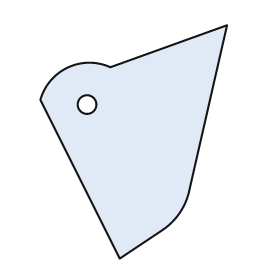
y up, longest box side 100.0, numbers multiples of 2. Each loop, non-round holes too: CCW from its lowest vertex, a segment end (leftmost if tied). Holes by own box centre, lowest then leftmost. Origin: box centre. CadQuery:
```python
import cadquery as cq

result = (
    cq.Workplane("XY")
    .moveTo(-6.0, -50.0)
    .lineTo(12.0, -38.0)
    .threePointArc((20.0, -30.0), (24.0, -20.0))
    .lineTo(40.0, 50.0)
    .lineTo(-10.0, 32.0)
    .threePointArc((-28.0, 32.0), (-40.0, 18.0))
    .close()
    .moveTo(-20.0, 16.0)
    .circle(4.0)
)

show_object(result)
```